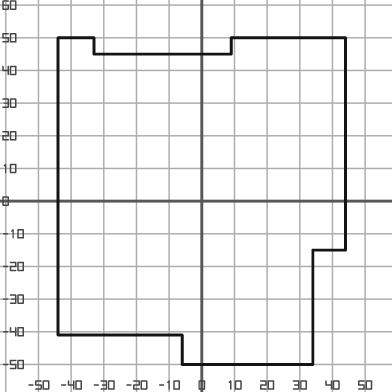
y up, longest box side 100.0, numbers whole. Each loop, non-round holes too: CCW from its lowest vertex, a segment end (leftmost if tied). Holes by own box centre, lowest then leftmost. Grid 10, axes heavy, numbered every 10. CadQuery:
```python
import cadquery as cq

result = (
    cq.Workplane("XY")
    .moveTo(-6.0, -50.0)
    .lineTo(34.0, -50.0)
    .lineTo(34.0, -15.0)
    .lineTo(44.0, -15.0)
    .lineTo(44.0, 50.0)
    .lineTo(9.0, 50.0)
    .lineTo(9.0, 45.0)
    .lineTo(-33.0, 45.0)
    .lineTo(-33.0, 50.0)
    .lineTo(-44.0, 50.0)
    .lineTo(-44.0, -41.0)
    .lineTo(-6.0, -41.0)
    .close()
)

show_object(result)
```